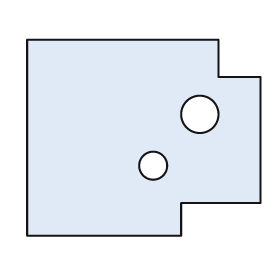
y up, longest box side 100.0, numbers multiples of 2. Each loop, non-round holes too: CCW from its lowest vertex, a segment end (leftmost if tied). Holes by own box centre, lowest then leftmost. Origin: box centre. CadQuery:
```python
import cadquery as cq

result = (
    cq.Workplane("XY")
    .moveTo(-50.0, -42.0)
    .lineTo(16.0, -42.0)
    .lineTo(16.0, -28.0)
    .lineTo(50.0, -28.0)
    .lineTo(50.0, 26.0)
    .lineTo(32.0, 26.0)
    .lineTo(32.0, 42.0)
    .lineTo(-50.0, 42.0)
    .close()
    .moveTo(4.0, -12.0)
    .circle(6.0)
    .moveTo(24.0, 10.0)
    .circle(8.0)
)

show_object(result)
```